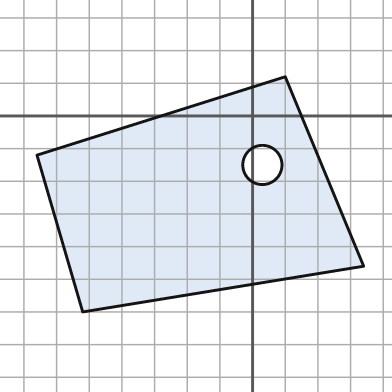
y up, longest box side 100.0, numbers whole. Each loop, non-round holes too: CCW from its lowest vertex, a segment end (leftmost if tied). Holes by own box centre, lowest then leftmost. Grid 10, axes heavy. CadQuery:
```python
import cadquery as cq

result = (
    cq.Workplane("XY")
    .moveTo(-52.0, -60.0)
    .lineTo(34.0, -46.0)
    .lineTo(10.0, 12.0)
    .lineTo(-66.0, -12.0)
    .close()
    .moveTo(3.0, -15.0)
    .circle(6.0)
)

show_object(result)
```